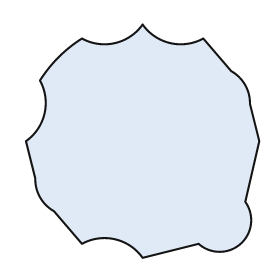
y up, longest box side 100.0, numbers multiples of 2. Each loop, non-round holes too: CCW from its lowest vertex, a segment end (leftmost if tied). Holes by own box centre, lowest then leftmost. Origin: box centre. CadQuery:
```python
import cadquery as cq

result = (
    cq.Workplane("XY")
    .moveTo(0.0, -50.0)
    .lineTo(24.0, -44.0)
    .threePointArc((42.0, -44.0), (44.0, -26.0))
    .lineTo(50.0, 0.0)
    .lineTo(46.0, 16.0)
    .threePointArc((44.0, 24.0), (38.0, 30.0))
    .lineTo(26.0, 44.0)
    .threePointArc((12.0, 42.0), (0.0, 50.0))
    .threePointArc((-12.0, 42.0), (-26.0, 44.0))
    .threePointArc((-36.0, 36.0), (-44.0, 26.0))
    .threePointArc((-42.0, 12.0), (-50.0, 0.0))
    .lineTo(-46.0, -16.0)
    .threePointArc((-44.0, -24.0), (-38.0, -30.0))
    .lineTo(-26.0, -44.0)
    .threePointArc((-12.0, -42.0), (0.0, -50.0))
    .close()
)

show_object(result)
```